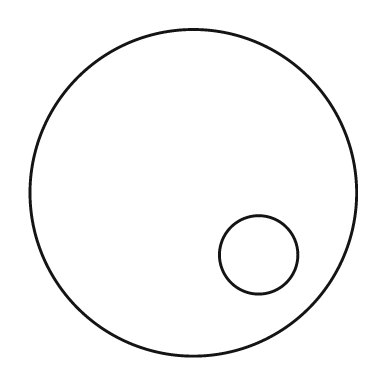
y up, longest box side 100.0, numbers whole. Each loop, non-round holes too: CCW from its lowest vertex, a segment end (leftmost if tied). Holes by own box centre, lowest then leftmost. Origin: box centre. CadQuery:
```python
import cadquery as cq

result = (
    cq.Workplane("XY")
    .moveTo(0.0, 0.0)
    .circle(50.0)
    .moveTo(20.0, -19.0)
    .circle(12.0)
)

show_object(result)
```